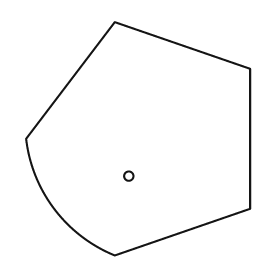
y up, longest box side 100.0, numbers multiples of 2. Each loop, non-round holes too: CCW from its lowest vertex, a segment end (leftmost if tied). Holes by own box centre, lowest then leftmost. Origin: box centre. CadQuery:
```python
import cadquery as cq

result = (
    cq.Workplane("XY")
    .moveTo(-10.0, -50.0)
    .lineTo(48.0, -30.0)
    .lineTo(48.0, 30.0)
    .lineTo(-10.0, 50.0)
    .lineTo(-48.0, 0.0)
    .threePointArc((-36.0, -30.0), (-10.0, -50.0))
    .close()
    .moveTo(-4.0, -16.0)
    .circle(2.0)
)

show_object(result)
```